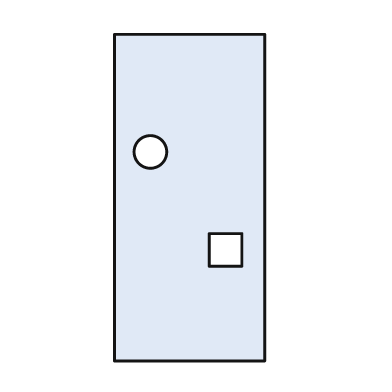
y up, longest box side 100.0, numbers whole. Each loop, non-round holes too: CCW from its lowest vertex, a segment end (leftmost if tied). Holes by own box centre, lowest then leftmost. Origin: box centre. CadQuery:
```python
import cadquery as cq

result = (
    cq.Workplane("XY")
    .moveTo(-23.0, -50.0)
    .lineTo(23.0, -50.0)
    .lineTo(23.0, 50.0)
    .lineTo(-23.0, 50.0)
    .close()
    .moveTo(6.0, -21.0)
    .lineTo(16.0, -21.0)
    .lineTo(16.0, -11.0)
    .lineTo(6.0, -11.0)
    .close()
    .moveTo(-12.0, 14.0)
    .circle(5.0)
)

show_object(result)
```